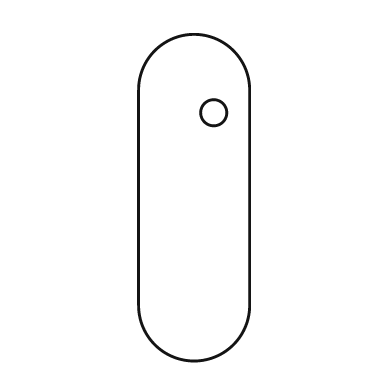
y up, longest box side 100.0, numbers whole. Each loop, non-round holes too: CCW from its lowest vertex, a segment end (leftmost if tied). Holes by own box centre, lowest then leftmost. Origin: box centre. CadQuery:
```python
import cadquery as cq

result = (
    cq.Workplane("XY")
    .moveTo(-17.0, -33.0)
    .threePointArc((0.0, -50.0), (17.0, -33.0))
    .lineTo(17.0, 33.0)
    .threePointArc((0.0, 50.0), (-17.0, 33.0))
    .close()
    .moveTo(6.0, 26.0)
    .circle(4.0)
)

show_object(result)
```